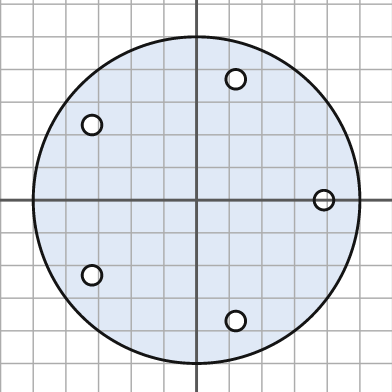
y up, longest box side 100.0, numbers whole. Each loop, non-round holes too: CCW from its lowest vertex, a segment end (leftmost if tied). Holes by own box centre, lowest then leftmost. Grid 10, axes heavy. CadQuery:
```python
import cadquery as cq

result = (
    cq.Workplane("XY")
    .moveTo(0.0, 0.0)
    .circle(50.0)
    .moveTo(12.0, -37.0)
    .circle(3.0)
    .moveTo(-32.0, -23.0)
    .circle(3.0)
    .moveTo(39.0, 0.0)
    .circle(3.0)
    .moveTo(-32.0, 23.0)
    .circle(3.0)
    .moveTo(12.0, 37.0)
    .circle(3.0)
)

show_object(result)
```